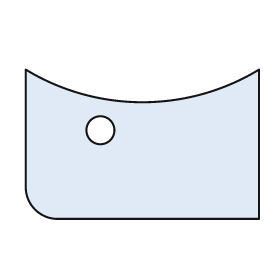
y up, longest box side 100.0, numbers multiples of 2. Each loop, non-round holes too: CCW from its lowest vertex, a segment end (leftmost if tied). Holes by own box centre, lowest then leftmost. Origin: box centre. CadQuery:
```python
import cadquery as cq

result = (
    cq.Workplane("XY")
    .moveTo(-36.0, -32.0)
    .lineTo(50.0, -32.0)
    .lineTo(50.0, 32.0)
    .threePointArc((0.0, 18.0), (-50.0, 32.0))
    .lineTo(-50.0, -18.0)
    .threePointArc((-46.0, -28.0), (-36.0, -32.0))
    .close()
    .moveTo(-18.0, 6.0)
    .circle(6.0)
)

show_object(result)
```